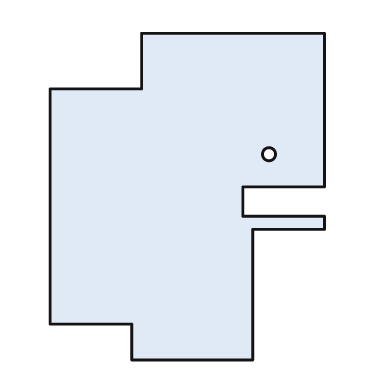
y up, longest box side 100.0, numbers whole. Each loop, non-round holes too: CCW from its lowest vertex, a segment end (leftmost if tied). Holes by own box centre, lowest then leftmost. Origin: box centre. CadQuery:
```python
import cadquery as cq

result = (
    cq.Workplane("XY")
    .moveTo(-17.0, -50.0)
    .lineTo(20.0, -50.0)
    .lineTo(20.0, -10.0)
    .lineTo(42.0, -10.0)
    .lineTo(42.0, -6.0)
    .lineTo(17.0, -6.0)
    .lineTo(17.0, 3.0)
    .lineTo(42.0, 3.0)
    .lineTo(42.0, 50.0)
    .lineTo(-14.0, 50.0)
    .lineTo(-14.0, 33.0)
    .lineTo(-42.0, 33.0)
    .lineTo(-42.0, -39.0)
    .lineTo(-17.0, -39.0)
    .close()
    .moveTo(25.0, 13.0)
    .circle(2.0)
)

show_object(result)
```